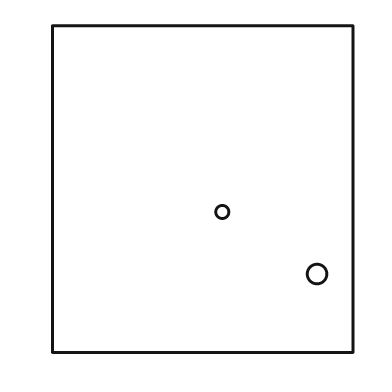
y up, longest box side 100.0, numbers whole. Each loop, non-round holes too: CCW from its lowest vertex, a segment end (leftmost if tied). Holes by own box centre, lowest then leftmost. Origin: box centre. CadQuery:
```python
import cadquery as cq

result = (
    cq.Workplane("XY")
    .moveTo(-46.0, -50.0)
    .lineTo(46.0, -50.0)
    .lineTo(46.0, 50.0)
    .lineTo(-46.0, 50.0)
    .close()
    .moveTo(35.0, -26.0)
    .circle(3.0)
    .moveTo(6.0, -7.0)
    .circle(2.0)
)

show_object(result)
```